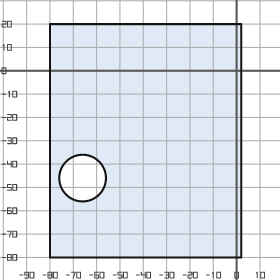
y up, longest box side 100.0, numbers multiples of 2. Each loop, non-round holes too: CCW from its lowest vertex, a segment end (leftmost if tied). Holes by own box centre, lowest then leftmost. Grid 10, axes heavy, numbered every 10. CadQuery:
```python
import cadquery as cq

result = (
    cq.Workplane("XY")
    .moveTo(-80.0, -80.0)
    .lineTo(2.0, -80.0)
    .lineTo(2.0, 20.0)
    .lineTo(-80.0, 20.0)
    .close()
    .moveTo(-66.0, -46.0)
    .circle(10.0)
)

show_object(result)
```